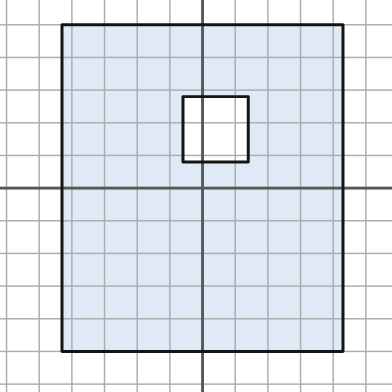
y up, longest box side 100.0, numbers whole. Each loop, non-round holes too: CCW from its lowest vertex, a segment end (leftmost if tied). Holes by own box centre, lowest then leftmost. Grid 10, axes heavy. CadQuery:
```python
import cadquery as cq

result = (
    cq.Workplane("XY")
    .moveTo(-43.0, -50.0)
    .lineTo(43.0, -50.0)
    .lineTo(43.0, 50.0)
    .lineTo(-43.0, 50.0)
    .close()
    .moveTo(-6.0, 8.0)
    .lineTo(14.0, 8.0)
    .lineTo(14.0, 28.0)
    .lineTo(-6.0, 28.0)
    .close()
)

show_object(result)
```